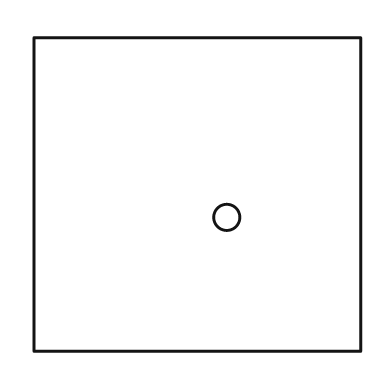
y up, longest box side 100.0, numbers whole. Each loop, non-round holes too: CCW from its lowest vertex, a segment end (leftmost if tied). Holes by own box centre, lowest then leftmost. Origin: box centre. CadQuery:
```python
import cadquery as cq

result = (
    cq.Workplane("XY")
    .moveTo(-50.0, -48.0)
    .lineTo(50.0, -48.0)
    .lineTo(50.0, 48.0)
    .lineTo(-50.0, 48.0)
    .close()
    .moveTo(9.0, -7.0)
    .circle(4.0)
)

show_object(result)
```